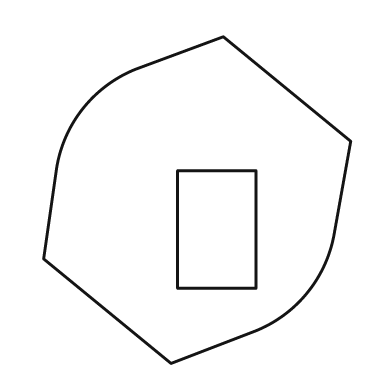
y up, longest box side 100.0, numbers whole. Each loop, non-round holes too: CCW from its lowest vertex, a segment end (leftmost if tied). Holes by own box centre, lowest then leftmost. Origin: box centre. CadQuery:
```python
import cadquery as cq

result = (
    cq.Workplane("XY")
    .moveTo(-8.0, -50.0)
    .lineTo(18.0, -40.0)
    .threePointArc((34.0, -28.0), (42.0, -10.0))
    .lineTo(47.0, 18.0)
    .lineTo(8.0, 50.0)
    .lineTo(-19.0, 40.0)
    .threePointArc((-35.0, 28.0), (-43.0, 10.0))
    .lineTo(-47.0, -18.0)
    .close()
    .moveTo(-6.0, -27.0)
    .lineTo(18.0, -27.0)
    .lineTo(18.0, 9.0)
    .lineTo(-6.0, 9.0)
    .close()
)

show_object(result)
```